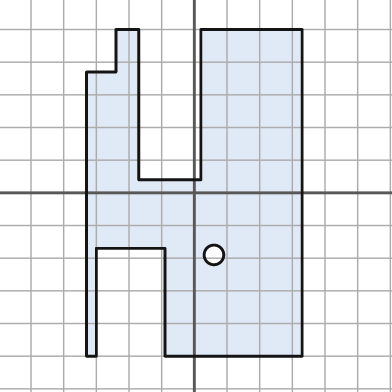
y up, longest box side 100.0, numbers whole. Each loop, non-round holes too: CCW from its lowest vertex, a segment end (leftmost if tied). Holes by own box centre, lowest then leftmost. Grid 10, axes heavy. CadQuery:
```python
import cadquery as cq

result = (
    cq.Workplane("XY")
    .moveTo(-33.0, -50.0)
    .lineTo(-30.0, -50.0)
    .lineTo(-30.0, -17.0)
    .lineTo(-9.0, -17.0)
    .lineTo(-9.0, -50.0)
    .lineTo(33.0, -50.0)
    .lineTo(33.0, 50.0)
    .lineTo(2.0, 50.0)
    .lineTo(2.0, 4.0)
    .lineTo(-17.0, 4.0)
    .lineTo(-17.0, 50.0)
    .lineTo(-24.0, 50.0)
    .lineTo(-24.0, 37.0)
    .lineTo(-33.0, 37.0)
    .close()
    .moveTo(6.0, -19.0)
    .circle(3.0)
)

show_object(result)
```